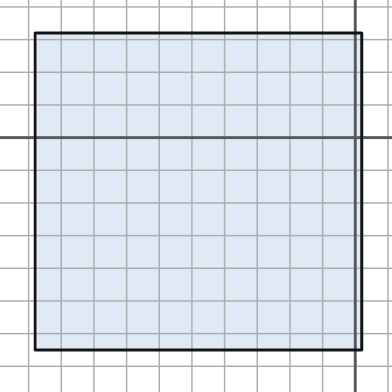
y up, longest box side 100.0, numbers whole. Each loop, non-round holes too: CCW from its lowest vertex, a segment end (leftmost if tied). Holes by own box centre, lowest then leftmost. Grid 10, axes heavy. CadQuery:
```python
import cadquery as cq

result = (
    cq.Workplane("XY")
    .moveTo(-98.0, -65.0)
    .lineTo(2.0, -65.0)
    .lineTo(2.0, 32.0)
    .lineTo(-98.0, 32.0)
    .close()
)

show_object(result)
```